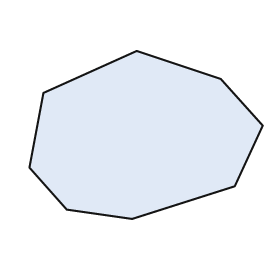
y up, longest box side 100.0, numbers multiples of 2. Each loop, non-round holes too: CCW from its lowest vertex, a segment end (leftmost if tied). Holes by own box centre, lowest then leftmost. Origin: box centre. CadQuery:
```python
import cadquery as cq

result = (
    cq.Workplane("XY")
    .moveTo(-6.0, -36.0)
    .lineTo(38.0, -22.0)
    .lineTo(50.0, 4.0)
    .lineTo(32.0, 24.0)
    .lineTo(-4.0, 36.0)
    .lineTo(-44.0, 18.0)
    .lineTo(-50.0, -14.0)
    .lineTo(-34.0, -32.0)
    .close()
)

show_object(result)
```